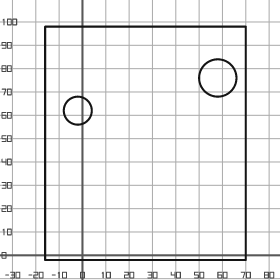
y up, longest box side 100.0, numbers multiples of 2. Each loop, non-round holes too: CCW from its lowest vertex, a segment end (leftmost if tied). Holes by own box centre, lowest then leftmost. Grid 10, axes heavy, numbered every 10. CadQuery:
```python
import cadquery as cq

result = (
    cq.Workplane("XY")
    .moveTo(-16.0, -2.0)
    .lineTo(70.0, -2.0)
    .lineTo(70.0, 98.0)
    .lineTo(-16.0, 98.0)
    .close()
    .moveTo(-2.0, 62.0)
    .circle(6.0)
    .moveTo(58.0, 76.0)
    .circle(8.0)
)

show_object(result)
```